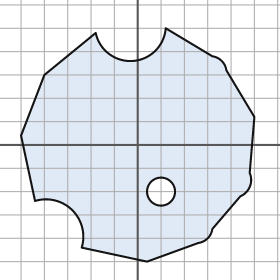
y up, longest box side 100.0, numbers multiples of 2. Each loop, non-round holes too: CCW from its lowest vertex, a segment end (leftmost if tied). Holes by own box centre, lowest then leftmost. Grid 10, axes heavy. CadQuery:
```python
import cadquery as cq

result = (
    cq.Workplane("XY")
    .moveTo(4.0, -50.0)
    .lineTo(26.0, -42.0)
    .threePointArc((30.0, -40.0), (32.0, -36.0))
    .lineTo(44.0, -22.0)
    .threePointArc((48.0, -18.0), (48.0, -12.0))
    .lineTo(50.0, 12.0)
    .lineTo(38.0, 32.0)
    .threePointArc((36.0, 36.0), (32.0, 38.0))
    .lineTo(12.0, 50.0)
    .threePointArc((-2.0, 36.0), (-18.0, 48.0))
    .lineTo(-40.0, 30.0)
    .lineTo(-50.0, 4.0)
    .lineTo(-44.0, -24.0)
    .threePointArc((-28.0, -28.0), (-24.0, -44.0))
    .close()
    .moveTo(10.0, -20.0)
    .circle(6.0)
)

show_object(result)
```